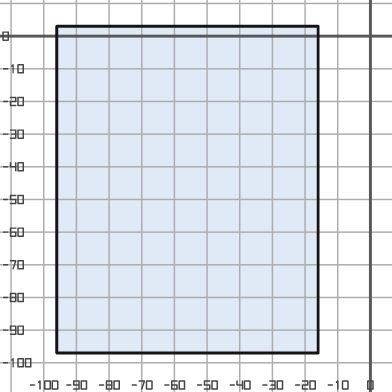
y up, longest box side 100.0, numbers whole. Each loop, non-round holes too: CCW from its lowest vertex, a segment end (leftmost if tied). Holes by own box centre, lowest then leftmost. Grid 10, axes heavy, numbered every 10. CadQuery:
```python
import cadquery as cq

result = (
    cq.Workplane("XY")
    .moveTo(-96.0, -97.0)
    .lineTo(-16.0, -97.0)
    .lineTo(-16.0, 3.0)
    .lineTo(-96.0, 3.0)
    .close()
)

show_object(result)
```